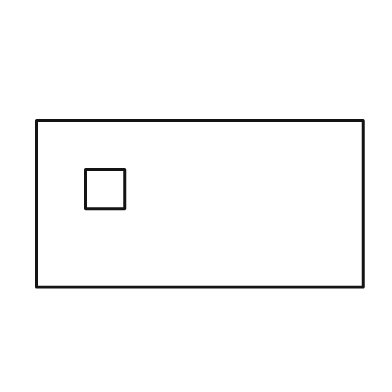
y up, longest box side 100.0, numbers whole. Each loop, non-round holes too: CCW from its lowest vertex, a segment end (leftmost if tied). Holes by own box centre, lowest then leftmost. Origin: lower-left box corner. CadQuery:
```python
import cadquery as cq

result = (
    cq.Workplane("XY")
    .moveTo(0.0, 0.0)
    .lineTo(100.0, 0.0)
    .lineTo(100.0, 51.0)
    .lineTo(0.0, 51.0)
    .close()
    .moveTo(15.0, 24.0)
    .lineTo(27.0, 24.0)
    .lineTo(27.0, 36.0)
    .lineTo(15.0, 36.0)
    .close()
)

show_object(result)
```